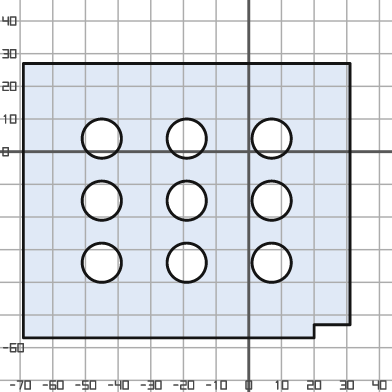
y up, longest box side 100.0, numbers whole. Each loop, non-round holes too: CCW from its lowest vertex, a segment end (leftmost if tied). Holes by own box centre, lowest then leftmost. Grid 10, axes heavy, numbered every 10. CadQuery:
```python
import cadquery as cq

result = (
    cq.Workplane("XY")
    .moveTo(-69.0, -57.0)
    .lineTo(20.0, -57.0)
    .lineTo(20.0, -53.0)
    .lineTo(31.0, -53.0)
    .lineTo(31.0, 27.0)
    .lineTo(-69.0, 27.0)
    .close()
    .moveTo(-45.0, -34.0)
    .circle(6.0)
    .moveTo(-19.0, -34.0)
    .circle(6.0)
    .moveTo(7.0, -34.0)
    .circle(6.0)
    .moveTo(-45.0, -15.0)
    .circle(6.0)
    .moveTo(-19.0, -15.0)
    .circle(6.0)
    .moveTo(7.0, -15.0)
    .circle(6.0)
    .moveTo(-45.0, 4.0)
    .circle(6.0)
    .moveTo(-19.0, 4.0)
    .circle(6.0)
    .moveTo(7.0, 4.0)
    .circle(6.0)
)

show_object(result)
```